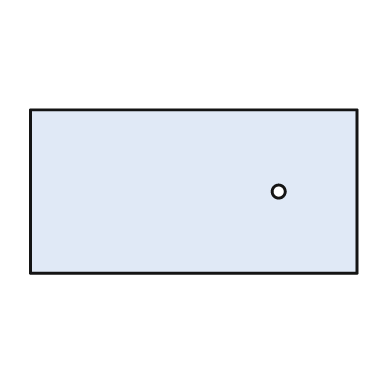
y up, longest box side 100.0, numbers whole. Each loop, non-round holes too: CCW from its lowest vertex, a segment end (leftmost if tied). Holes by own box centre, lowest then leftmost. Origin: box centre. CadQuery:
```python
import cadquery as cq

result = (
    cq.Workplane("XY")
    .moveTo(-50.0, -25.0)
    .lineTo(50.0, -25.0)
    .lineTo(50.0, 25.0)
    .lineTo(-50.0, 25.0)
    .close()
    .moveTo(26.0, 0.0)
    .circle(2.0)
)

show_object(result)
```